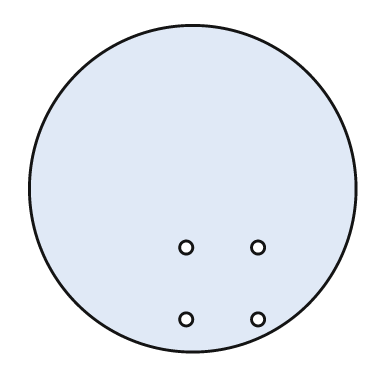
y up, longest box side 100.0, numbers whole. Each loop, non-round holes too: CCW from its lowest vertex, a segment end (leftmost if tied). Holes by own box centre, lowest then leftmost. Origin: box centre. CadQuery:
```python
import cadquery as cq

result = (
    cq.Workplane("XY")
    .moveTo(0.0, 0.0)
    .circle(50.0)
    .moveTo(-2.0, -40.0)
    .circle(2.0)
    .moveTo(20.0, -40.0)
    .circle(2.0)
    .moveTo(-2.0, -18.0)
    .circle(2.0)
    .moveTo(20.0, -18.0)
    .circle(2.0)
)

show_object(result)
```